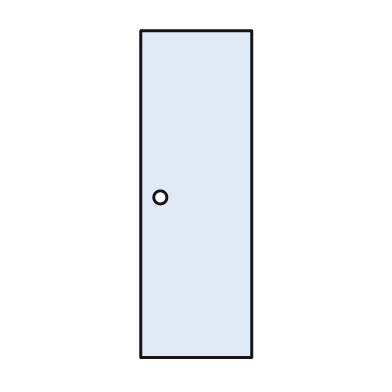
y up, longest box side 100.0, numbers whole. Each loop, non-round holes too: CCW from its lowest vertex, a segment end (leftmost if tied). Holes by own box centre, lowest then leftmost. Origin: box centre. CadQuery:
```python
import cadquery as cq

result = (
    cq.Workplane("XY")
    .moveTo(-17.0, -50.0)
    .lineTo(17.0, -50.0)
    .lineTo(17.0, 50.0)
    .lineTo(-17.0, 50.0)
    .close()
    .moveTo(-11.0, -1.0)
    .circle(2.0)
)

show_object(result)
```